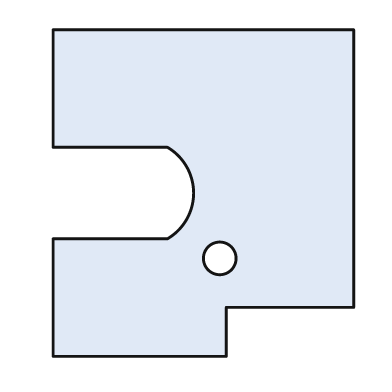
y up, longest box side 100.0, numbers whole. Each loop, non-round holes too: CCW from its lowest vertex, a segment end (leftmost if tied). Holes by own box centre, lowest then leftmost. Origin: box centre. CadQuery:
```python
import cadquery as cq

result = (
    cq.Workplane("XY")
    .moveTo(-46.0, -50.0)
    .lineTo(7.0, -50.0)
    .lineTo(7.0, -35.0)
    .lineTo(46.0, -35.0)
    .lineTo(46.0, 50.0)
    .lineTo(-46.0, 50.0)
    .lineTo(-46.0, 14.0)
    .lineTo(-11.0, 14.0)
    .threePointArc((-3.0, 0.0), (-11.0, -14.0))
    .lineTo(-46.0, -14.0)
    .close()
    .moveTo(5.0, -20.0)
    .circle(5.0)
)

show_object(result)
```